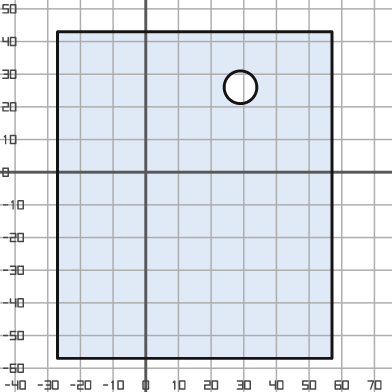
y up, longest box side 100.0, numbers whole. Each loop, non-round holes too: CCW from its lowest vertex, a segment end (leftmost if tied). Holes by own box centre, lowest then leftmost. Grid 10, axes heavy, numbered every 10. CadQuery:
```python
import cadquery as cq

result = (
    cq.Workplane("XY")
    .moveTo(-27.0, -57.0)
    .lineTo(57.0, -57.0)
    .lineTo(57.0, 43.0)
    .lineTo(-27.0, 43.0)
    .close()
    .moveTo(29.0, 26.0)
    .circle(5.0)
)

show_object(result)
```